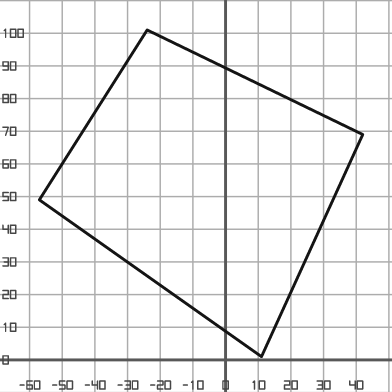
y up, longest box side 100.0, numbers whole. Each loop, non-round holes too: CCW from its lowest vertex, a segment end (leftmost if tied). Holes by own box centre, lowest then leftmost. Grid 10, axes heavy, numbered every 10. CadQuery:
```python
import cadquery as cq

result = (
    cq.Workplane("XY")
    .moveTo(11.0, 1.0)
    .lineTo(42.0, 69.0)
    .lineTo(-24.0, 101.0)
    .lineTo(-57.0, 49.0)
    .close()
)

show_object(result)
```